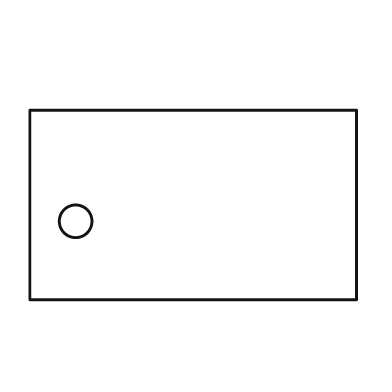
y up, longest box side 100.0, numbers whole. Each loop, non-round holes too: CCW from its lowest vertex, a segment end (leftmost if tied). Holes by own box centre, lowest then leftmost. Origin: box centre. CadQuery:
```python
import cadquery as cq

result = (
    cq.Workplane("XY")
    .moveTo(-50.0, -29.0)
    .lineTo(50.0, -29.0)
    .lineTo(50.0, 29.0)
    .lineTo(-50.0, 29.0)
    .close()
    .moveTo(-36.0, -5.0)
    .circle(5.0)
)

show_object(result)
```